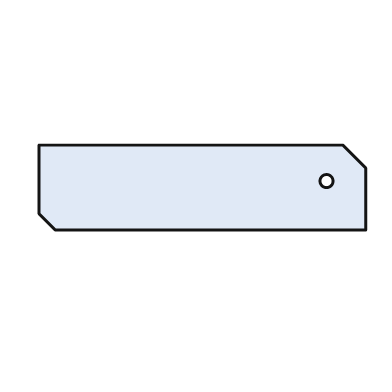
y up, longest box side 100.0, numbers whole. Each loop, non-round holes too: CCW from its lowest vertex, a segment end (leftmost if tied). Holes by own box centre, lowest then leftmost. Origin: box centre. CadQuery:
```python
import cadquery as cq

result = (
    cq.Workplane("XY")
    .moveTo(-45.0, -13.0)
    .lineTo(50.0, -13.0)
    .lineTo(50.0, 6.0)
    .lineTo(43.0, 13.0)
    .lineTo(-50.0, 13.0)
    .lineTo(-50.0, -8.0)
    .close()
    .moveTo(38.0, 2.0)
    .circle(2.0)
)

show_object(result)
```